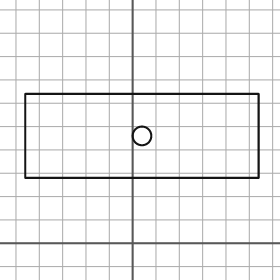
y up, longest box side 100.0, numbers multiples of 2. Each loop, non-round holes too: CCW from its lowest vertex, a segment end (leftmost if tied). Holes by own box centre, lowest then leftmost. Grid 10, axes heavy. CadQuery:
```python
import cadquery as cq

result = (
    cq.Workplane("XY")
    .moveTo(-46.0, 28.0)
    .lineTo(54.0, 28.0)
    .lineTo(54.0, 64.0)
    .lineTo(-46.0, 64.0)
    .close()
    .moveTo(4.0, 46.0)
    .circle(4.0)
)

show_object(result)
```